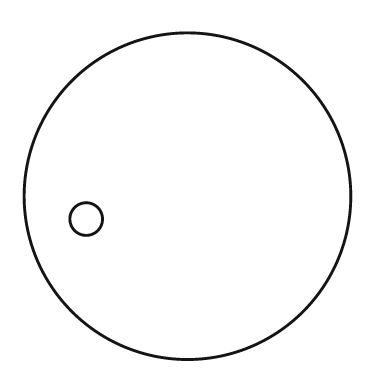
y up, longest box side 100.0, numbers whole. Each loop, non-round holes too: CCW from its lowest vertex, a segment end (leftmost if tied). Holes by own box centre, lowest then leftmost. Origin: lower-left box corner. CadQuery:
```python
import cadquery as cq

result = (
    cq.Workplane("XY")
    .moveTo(50.0, 50.0)
    .circle(50.0)
    .moveTo(19.0, 43.0)
    .circle(5.0)
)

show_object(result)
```